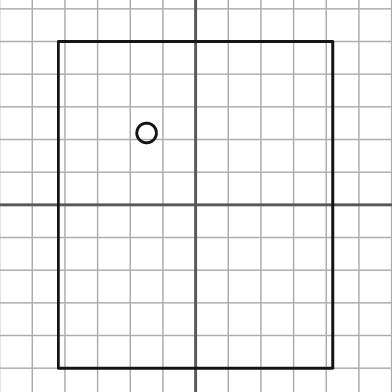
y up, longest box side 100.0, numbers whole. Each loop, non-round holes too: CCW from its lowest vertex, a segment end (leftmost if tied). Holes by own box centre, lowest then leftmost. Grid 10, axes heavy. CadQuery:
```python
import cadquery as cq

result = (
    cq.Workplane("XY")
    .moveTo(-42.0, -50.0)
    .lineTo(42.0, -50.0)
    .lineTo(42.0, 50.0)
    .lineTo(-42.0, 50.0)
    .close()
    .moveTo(-15.0, 22.0)
    .circle(3.0)
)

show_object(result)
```